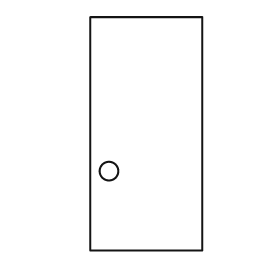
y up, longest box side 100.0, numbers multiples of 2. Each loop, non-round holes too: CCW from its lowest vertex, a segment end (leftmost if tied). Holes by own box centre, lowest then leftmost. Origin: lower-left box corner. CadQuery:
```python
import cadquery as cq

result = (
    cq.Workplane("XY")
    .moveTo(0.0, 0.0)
    .lineTo(48.0, 0.0)
    .lineTo(48.0, 100.0)
    .lineTo(0.0, 100.0)
    .close()
    .moveTo(8.0, 34.0)
    .circle(4.0)
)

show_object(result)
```